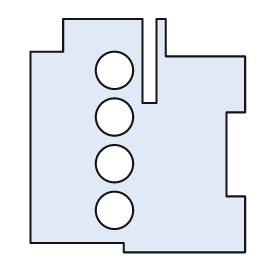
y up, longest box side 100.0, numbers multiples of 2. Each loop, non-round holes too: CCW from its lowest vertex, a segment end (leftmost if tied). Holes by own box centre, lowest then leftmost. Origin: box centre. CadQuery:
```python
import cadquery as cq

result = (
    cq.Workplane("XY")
    .moveTo(-6.0, -50.0)
    .lineTo(46.0, -50.0)
    .lineTo(46.0, -26.0)
    .lineTo(38.0, -26.0)
    .lineTo(38.0, 10.0)
    .lineTo(46.0, 10.0)
    .lineTo(46.0, 34.0)
    .lineTo(12.0, 34.0)
    .lineTo(12.0, 50.0)
    .lineTo(8.0, 50.0)
    .lineTo(8.0, 14.0)
    .lineTo(2.0, 14.0)
    .lineTo(2.0, 50.0)
    .lineTo(-32.0, 50.0)
    .lineTo(-32.0, 36.0)
    .lineTo(-46.0, 36.0)
    .lineTo(-46.0, -46.0)
    .lineTo(-6.0, -46.0)
    .close()
    .moveTo(-10.0, -32.0)
    .circle(8.0)
    .moveTo(-10.0, -12.0)
    .circle(8.0)
    .moveTo(-10.0, 8.0)
    .circle(8.0)
    .moveTo(-10.0, 28.0)
    .circle(8.0)
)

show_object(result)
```